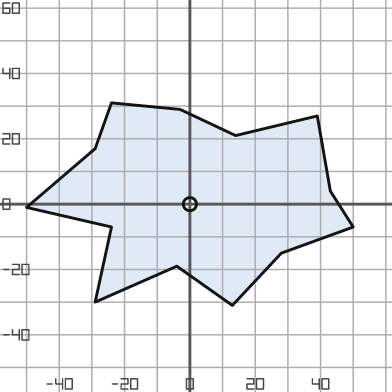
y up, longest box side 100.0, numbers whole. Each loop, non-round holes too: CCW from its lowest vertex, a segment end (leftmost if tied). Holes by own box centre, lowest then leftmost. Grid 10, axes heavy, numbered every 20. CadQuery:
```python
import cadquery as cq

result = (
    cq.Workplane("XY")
    .moveTo(13.0, -31.0)
    .lineTo(28.0, -15.0)
    .lineTo(50.0, -7.0)
    .lineTo(43.0, 4.0)
    .lineTo(39.0, 27.0)
    .lineTo(14.0, 21.0)
    .lineTo(-3.0, 29.0)
    .lineTo(-24.0, 31.0)
    .lineTo(-29.0, 17.0)
    .lineTo(-50.0, -1.0)
    .lineTo(-24.0, -7.0)
    .lineTo(-29.0, -30.0)
    .lineTo(-4.0, -19.0)
    .close()
    .moveTo(0.0, 0.0)
    .circle(2.0)
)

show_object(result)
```